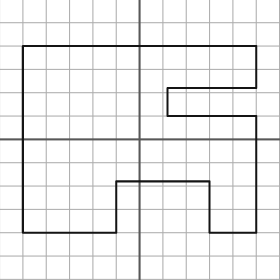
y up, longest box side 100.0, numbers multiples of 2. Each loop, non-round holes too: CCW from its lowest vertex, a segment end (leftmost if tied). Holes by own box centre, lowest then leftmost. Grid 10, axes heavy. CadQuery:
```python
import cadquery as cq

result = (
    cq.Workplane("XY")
    .moveTo(-50.0, -40.0)
    .lineTo(-10.0, -40.0)
    .lineTo(-10.0, -18.0)
    .lineTo(30.0, -18.0)
    .lineTo(30.0, -40.0)
    .lineTo(50.0, -40.0)
    .lineTo(50.0, 10.0)
    .lineTo(12.0, 10.0)
    .lineTo(12.0, 22.0)
    .lineTo(50.0, 22.0)
    .lineTo(50.0, 40.0)
    .lineTo(-50.0, 40.0)
    .close()
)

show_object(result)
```